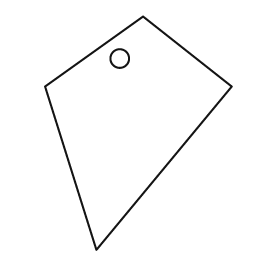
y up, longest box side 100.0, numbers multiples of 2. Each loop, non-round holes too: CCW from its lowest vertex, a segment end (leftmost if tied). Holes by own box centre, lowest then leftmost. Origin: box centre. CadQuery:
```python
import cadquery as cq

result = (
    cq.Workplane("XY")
    .moveTo(-18.0, -50.0)
    .lineTo(40.0, 20.0)
    .lineTo(2.0, 50.0)
    .lineTo(-40.0, 20.0)
    .close()
    .moveTo(-8.0, 32.0)
    .circle(4.0)
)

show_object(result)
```